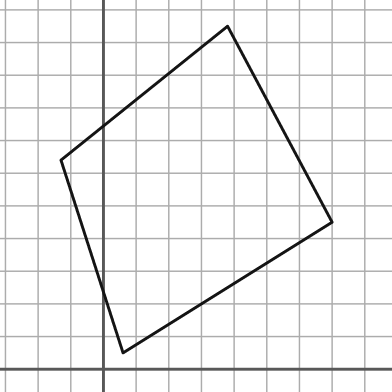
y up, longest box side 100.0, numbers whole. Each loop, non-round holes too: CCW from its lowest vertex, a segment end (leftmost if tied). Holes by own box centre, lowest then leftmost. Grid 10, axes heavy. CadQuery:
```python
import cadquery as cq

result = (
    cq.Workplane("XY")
    .moveTo(6.0, 5.0)
    .lineTo(70.0, 45.0)
    .lineTo(38.0, 105.0)
    .lineTo(-13.0, 64.0)
    .close()
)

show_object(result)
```